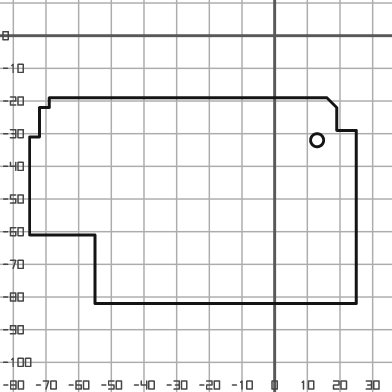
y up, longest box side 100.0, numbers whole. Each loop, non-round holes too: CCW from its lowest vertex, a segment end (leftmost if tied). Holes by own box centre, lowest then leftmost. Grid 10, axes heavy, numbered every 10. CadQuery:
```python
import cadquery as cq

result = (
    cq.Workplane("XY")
    .moveTo(-55.0, -82.0)
    .lineTo(25.0, -82.0)
    .lineTo(25.0, -29.0)
    .lineTo(19.0, -29.0)
    .lineTo(19.0, -22.0)
    .lineTo(16.0, -19.0)
    .lineTo(-69.0, -19.0)
    .lineTo(-69.0, -22.0)
    .lineTo(-72.0, -22.0)
    .lineTo(-72.0, -31.0)
    .lineTo(-75.0, -31.0)
    .lineTo(-75.0, -61.0)
    .lineTo(-55.0, -61.0)
    .close()
    .moveTo(13.0, -32.0)
    .circle(2.0)
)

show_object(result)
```